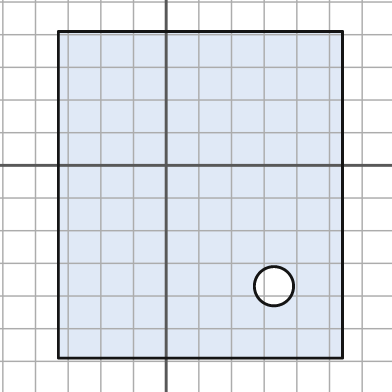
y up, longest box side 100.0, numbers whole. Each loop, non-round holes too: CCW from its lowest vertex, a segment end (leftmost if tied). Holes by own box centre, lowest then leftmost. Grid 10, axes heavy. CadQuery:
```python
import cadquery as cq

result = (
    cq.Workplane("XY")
    .moveTo(-33.0, -59.0)
    .lineTo(54.0, -59.0)
    .lineTo(54.0, 41.0)
    .lineTo(-33.0, 41.0)
    .close()
    .moveTo(33.0, -37.0)
    .circle(6.0)
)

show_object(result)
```